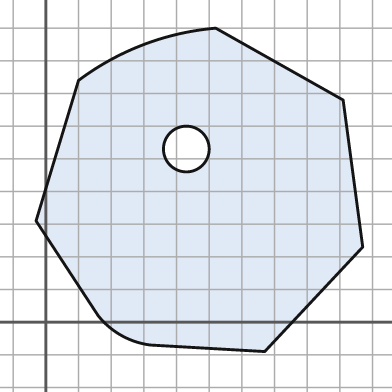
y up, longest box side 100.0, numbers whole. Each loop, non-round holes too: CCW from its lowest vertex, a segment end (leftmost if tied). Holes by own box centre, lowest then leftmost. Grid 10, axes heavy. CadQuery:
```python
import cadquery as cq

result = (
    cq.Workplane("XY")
    .moveTo(67.0, -9.0)
    .lineTo(97.0, 23.0)
    .lineTo(91.0, 68.0)
    .lineTo(52.0, 90.0)
    .threePointArc((30.0, 85.0), (10.0, 74.0))
    .lineTo(-3.0, 31.0)
    .lineTo(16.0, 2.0)
    .threePointArc((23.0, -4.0), (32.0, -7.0))
    .close()
    .moveTo(43.0, 53.0)
    .circle(7.0)
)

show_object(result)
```